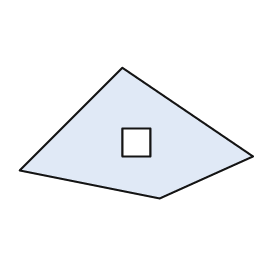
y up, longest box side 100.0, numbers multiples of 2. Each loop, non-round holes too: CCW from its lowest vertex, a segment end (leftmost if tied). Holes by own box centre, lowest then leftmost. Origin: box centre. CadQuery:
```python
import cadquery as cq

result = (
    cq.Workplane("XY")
    .moveTo(10.0, -28.0)
    .lineTo(50.0, -10.0)
    .lineTo(-6.0, 28.0)
    .lineTo(-50.0, -16.0)
    .close()
    .moveTo(-6.0, -10.0)
    .lineTo(6.0, -10.0)
    .lineTo(6.0, 2.0)
    .lineTo(-6.0, 2.0)
    .close()
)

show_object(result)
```